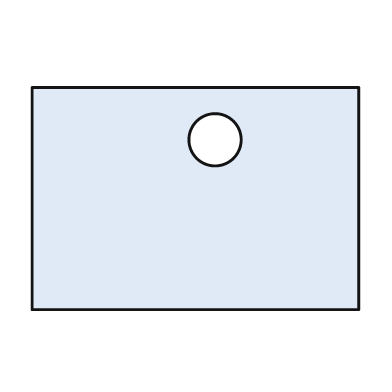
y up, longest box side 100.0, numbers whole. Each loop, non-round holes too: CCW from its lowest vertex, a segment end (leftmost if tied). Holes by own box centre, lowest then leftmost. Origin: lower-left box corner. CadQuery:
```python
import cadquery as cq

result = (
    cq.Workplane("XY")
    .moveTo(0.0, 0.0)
    .lineTo(100.0, 0.0)
    .lineTo(100.0, 68.0)
    .lineTo(0.0, 68.0)
    .close()
    .moveTo(56.0, 52.0)
    .circle(8.0)
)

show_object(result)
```